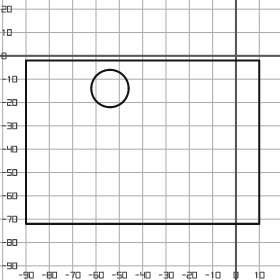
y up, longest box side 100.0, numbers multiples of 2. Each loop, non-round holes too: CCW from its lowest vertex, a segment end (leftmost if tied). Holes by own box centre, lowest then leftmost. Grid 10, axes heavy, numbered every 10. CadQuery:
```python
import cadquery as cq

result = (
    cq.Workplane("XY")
    .moveTo(-90.0, -72.0)
    .lineTo(10.0, -72.0)
    .lineTo(10.0, -2.0)
    .lineTo(-90.0, -2.0)
    .close()
    .moveTo(-54.0, -14.0)
    .circle(8.0)
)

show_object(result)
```